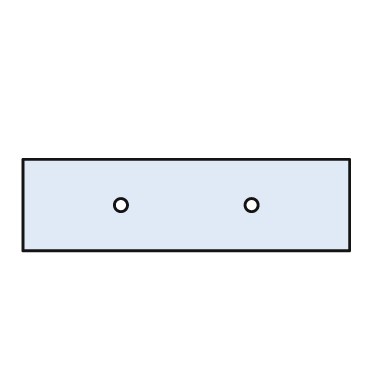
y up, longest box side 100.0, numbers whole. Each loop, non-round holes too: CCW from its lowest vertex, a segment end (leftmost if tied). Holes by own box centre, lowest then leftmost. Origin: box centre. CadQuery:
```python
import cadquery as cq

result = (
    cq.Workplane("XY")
    .moveTo(-50.0, -14.0)
    .lineTo(50.0, -14.0)
    .lineTo(50.0, 14.0)
    .lineTo(-50.0, 14.0)
    .close()
    .moveTo(-20.0, 0.0)
    .circle(2.0)
    .moveTo(20.0, 0.0)
    .circle(2.0)
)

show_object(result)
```